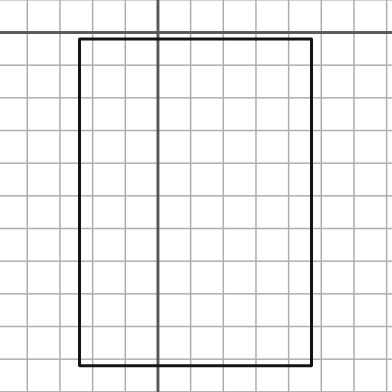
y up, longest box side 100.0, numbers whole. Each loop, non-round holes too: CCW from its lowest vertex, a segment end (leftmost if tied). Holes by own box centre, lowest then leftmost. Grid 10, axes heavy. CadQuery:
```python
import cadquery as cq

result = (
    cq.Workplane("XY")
    .moveTo(-24.0, -102.0)
    .lineTo(47.0, -102.0)
    .lineTo(47.0, -2.0)
    .lineTo(-24.0, -2.0)
    .close()
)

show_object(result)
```